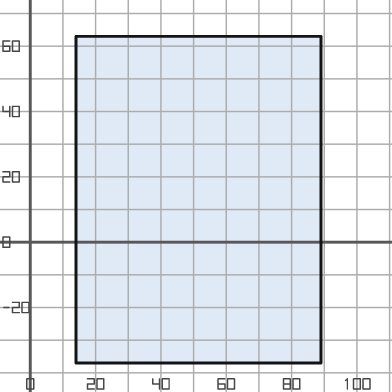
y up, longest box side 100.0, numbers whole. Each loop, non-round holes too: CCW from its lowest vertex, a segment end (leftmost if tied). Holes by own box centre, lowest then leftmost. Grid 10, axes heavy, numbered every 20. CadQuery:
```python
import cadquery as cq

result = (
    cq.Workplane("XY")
    .moveTo(14.0, -37.0)
    .lineTo(89.0, -37.0)
    .lineTo(89.0, 63.0)
    .lineTo(14.0, 63.0)
    .close()
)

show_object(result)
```